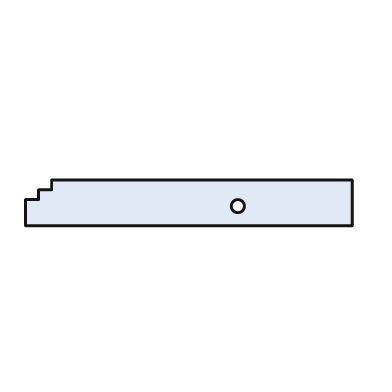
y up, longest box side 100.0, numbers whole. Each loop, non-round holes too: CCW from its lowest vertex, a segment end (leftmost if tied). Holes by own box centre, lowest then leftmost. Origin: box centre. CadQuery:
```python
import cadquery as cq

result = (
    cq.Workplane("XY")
    .moveTo(-50.0, -7.0)
    .lineTo(50.0, -7.0)
    .lineTo(50.0, 7.0)
    .lineTo(-42.0, 7.0)
    .lineTo(-42.0, 4.0)
    .lineTo(-46.0, 4.0)
    .lineTo(-46.0, 1.0)
    .lineTo(-50.0, 1.0)
    .close()
    .moveTo(15.0, -1.0)
    .circle(2.0)
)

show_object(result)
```